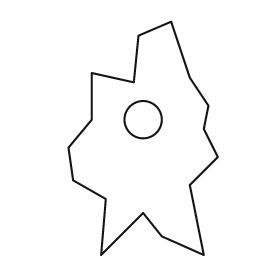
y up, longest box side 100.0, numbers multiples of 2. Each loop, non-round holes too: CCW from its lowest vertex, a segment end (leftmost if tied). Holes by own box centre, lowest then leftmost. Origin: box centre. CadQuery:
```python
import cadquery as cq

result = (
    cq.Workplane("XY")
    .moveTo(-18.0, -50.0)
    .lineTo(0.0, -32.0)
    .lineTo(8.0, -42.0)
    .lineTo(26.0, -50.0)
    .lineTo(20.0, -20.0)
    .lineTo(32.0, -8.0)
    .lineTo(26.0, 4.0)
    .lineTo(28.0, 14.0)
    .lineTo(20.0, 26.0)
    .lineTo(12.0, 50.0)
    .lineTo(-2.0, 44.0)
    .lineTo(-4.0, 24.0)
    .lineTo(-22.0, 28.0)
    .lineTo(-22.0, 8.0)
    .lineTo(-32.0, -4.0)
    .lineTo(-30.0, -18.0)
    .lineTo(-16.0, -26.0)
    .close()
    .moveTo(0.0, 8.0)
    .circle(8.0)
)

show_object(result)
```